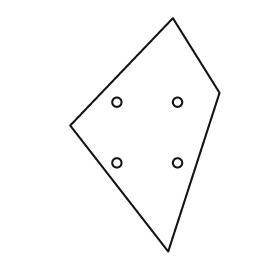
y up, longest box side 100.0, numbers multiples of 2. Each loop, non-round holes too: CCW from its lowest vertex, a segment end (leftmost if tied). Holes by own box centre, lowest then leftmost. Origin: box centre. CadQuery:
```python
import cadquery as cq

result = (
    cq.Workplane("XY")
    .moveTo(10.0, -50.0)
    .lineTo(32.0, 18.0)
    .lineTo(12.0, 50.0)
    .lineTo(-32.0, 4.0)
    .close()
    .moveTo(-12.0, -12.0)
    .circle(2.0)
    .moveTo(14.0, -12.0)
    .circle(2.0)
    .moveTo(-12.0, 14.0)
    .circle(2.0)
    .moveTo(14.0, 14.0)
    .circle(2.0)
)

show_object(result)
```